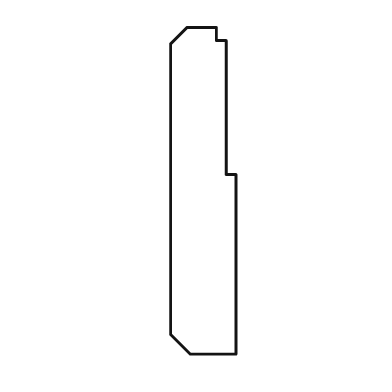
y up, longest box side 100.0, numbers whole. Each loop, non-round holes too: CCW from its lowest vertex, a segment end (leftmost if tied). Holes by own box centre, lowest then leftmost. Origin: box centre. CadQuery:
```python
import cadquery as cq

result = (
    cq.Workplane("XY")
    .moveTo(-4.0, -50.0)
    .lineTo(10.0, -50.0)
    .lineTo(10.0, 5.0)
    .lineTo(7.0, 5.0)
    .lineTo(7.0, 46.0)
    .lineTo(4.0, 46.0)
    .lineTo(4.0, 50.0)
    .lineTo(-5.0, 50.0)
    .lineTo(-10.0, 45.0)
    .lineTo(-10.0, -44.0)
    .close()
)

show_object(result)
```